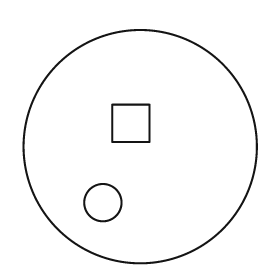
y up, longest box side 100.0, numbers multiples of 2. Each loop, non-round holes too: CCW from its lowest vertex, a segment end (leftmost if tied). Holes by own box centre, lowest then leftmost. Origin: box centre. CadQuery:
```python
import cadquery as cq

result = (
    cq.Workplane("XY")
    .moveTo(0.0, 0.0)
    .circle(50.0)
    .moveTo(-16.0, -24.0)
    .circle(8.0)
    .moveTo(-12.0, 2.0)
    .lineTo(4.0, 2.0)
    .lineTo(4.0, 18.0)
    .lineTo(-12.0, 18.0)
    .close()
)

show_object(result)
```